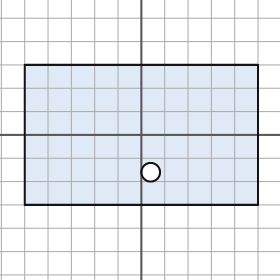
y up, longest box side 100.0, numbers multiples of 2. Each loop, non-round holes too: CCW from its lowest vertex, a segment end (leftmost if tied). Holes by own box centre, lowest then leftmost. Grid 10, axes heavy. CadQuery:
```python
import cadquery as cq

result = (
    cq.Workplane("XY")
    .moveTo(-50.0, -30.0)
    .lineTo(50.0, -30.0)
    .lineTo(50.0, 30.0)
    .lineTo(-50.0, 30.0)
    .close()
    .moveTo(4.0, -16.0)
    .circle(4.0)
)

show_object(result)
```